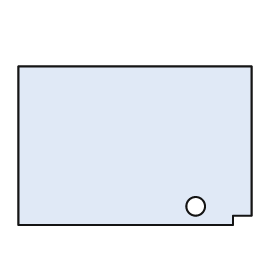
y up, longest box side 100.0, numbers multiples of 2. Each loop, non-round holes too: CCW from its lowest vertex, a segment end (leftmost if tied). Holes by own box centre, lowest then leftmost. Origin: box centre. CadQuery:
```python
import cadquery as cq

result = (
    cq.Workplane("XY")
    .moveTo(-50.0, -34.0)
    .lineTo(42.0, -34.0)
    .lineTo(42.0, -30.0)
    .lineTo(50.0, -30.0)
    .lineTo(50.0, 34.0)
    .lineTo(-50.0, 34.0)
    .close()
    .moveTo(26.0, -26.0)
    .circle(4.0)
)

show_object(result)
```